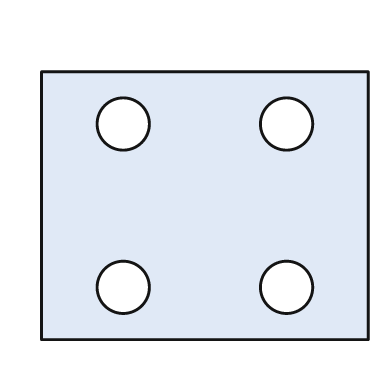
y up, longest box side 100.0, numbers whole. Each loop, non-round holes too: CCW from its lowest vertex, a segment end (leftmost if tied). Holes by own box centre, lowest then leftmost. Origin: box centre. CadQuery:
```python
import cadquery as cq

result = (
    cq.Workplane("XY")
    .moveTo(-50.0, -41.0)
    .lineTo(50.0, -41.0)
    .lineTo(50.0, 41.0)
    .lineTo(-50.0, 41.0)
    .close()
    .moveTo(-25.0, -25.0)
    .circle(8.0)
    .moveTo(25.0, -25.0)
    .circle(8.0)
    .moveTo(-25.0, 25.0)
    .circle(8.0)
    .moveTo(25.0, 25.0)
    .circle(8.0)
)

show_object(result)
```